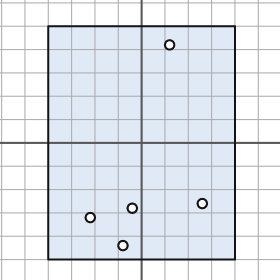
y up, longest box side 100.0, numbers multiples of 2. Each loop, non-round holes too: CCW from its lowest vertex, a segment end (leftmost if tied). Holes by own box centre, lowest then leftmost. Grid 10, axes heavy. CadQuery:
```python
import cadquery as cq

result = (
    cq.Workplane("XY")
    .moveTo(-40.0, -50.0)
    .lineTo(40.0, -50.0)
    .lineTo(40.0, 50.0)
    .lineTo(-40.0, 50.0)
    .close()
    .moveTo(-8.0, -44.0)
    .circle(2.0)
    .moveTo(-22.0, -32.0)
    .circle(2.0)
    .moveTo(-4.0, -28.0)
    .circle(2.0)
    .moveTo(26.0, -26.0)
    .circle(2.0)
    .moveTo(12.0, 42.0)
    .circle(2.0)
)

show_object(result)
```